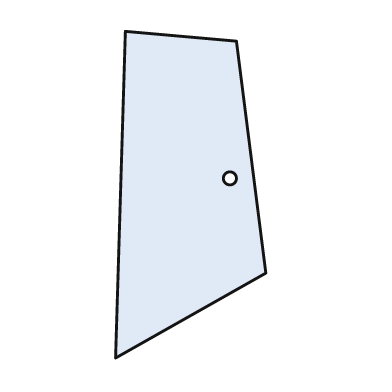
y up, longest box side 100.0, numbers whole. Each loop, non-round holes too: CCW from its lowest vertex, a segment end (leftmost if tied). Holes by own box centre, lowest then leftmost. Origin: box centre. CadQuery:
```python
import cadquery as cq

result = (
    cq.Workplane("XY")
    .moveTo(-23.0, -50.0)
    .lineTo(23.0, -24.0)
    .lineTo(14.0, 47.0)
    .lineTo(-20.0, 50.0)
    .close()
    .moveTo(12.0, 5.0)
    .circle(2.0)
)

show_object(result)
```